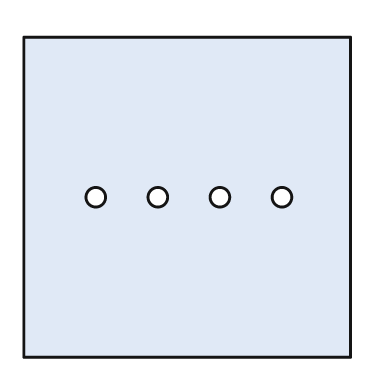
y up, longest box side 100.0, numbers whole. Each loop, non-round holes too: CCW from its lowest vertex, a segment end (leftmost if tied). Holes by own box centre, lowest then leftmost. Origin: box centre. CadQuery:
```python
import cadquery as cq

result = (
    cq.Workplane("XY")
    .moveTo(-50.0, -49.0)
    .lineTo(50.0, -49.0)
    .lineTo(50.0, 49.0)
    .lineTo(-50.0, 49.0)
    .close()
    .moveTo(-28.0, 0.0)
    .circle(3.0)
    .moveTo(-9.0, 0.0)
    .circle(3.0)
    .moveTo(10.0, 0.0)
    .circle(3.0)
    .moveTo(29.0, 0.0)
    .circle(3.0)
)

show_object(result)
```